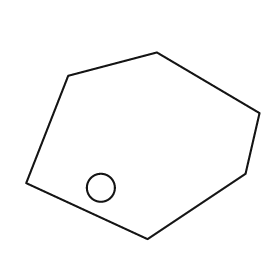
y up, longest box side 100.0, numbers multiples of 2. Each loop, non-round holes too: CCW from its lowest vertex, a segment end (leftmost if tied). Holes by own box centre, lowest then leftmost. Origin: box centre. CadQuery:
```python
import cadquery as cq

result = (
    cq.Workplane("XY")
    .moveTo(2.0, -40.0)
    .lineTo(44.0, -12.0)
    .lineTo(50.0, 14.0)
    .lineTo(6.0, 40.0)
    .lineTo(-32.0, 30.0)
    .lineTo(-50.0, -16.0)
    .close()
    .moveTo(-18.0, -18.0)
    .circle(6.0)
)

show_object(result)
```